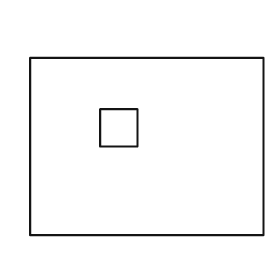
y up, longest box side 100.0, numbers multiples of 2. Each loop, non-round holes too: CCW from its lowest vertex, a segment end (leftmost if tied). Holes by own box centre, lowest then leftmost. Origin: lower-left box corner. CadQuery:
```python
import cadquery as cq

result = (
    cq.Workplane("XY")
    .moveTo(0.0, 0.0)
    .lineTo(100.0, 0.0)
    .lineTo(100.0, 76.0)
    .lineTo(0.0, 76.0)
    .close()
    .moveTo(30.0, 38.0)
    .lineTo(46.0, 38.0)
    .lineTo(46.0, 54.0)
    .lineTo(30.0, 54.0)
    .close()
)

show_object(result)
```